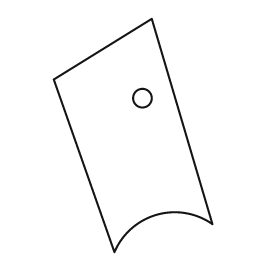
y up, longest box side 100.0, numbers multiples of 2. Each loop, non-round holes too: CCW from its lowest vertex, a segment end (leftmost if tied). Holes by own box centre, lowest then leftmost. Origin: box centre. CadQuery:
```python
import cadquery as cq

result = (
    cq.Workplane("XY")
    .moveTo(-8.0, -50.0)
    .threePointArc((10.0, -34.0), (34.0, -38.0))
    .lineTo(8.0, 50.0)
    .lineTo(-34.0, 24.0)
    .close()
    .moveTo(4.0, 16.0)
    .circle(4.0)
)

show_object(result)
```